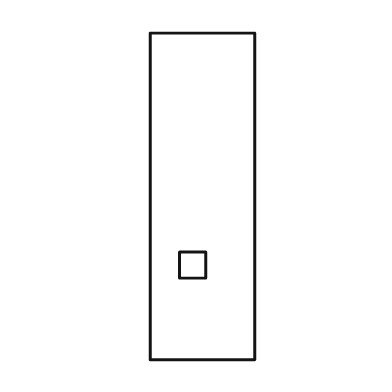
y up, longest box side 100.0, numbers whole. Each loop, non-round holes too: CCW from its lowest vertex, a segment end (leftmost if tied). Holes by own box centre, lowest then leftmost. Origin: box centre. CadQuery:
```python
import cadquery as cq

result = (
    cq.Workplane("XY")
    .moveTo(-16.0, -50.0)
    .lineTo(16.0, -50.0)
    .lineTo(16.0, 50.0)
    .lineTo(-16.0, 50.0)
    .close()
    .moveTo(-7.0, -25.0)
    .lineTo(1.0, -25.0)
    .lineTo(1.0, -17.0)
    .lineTo(-7.0, -17.0)
    .close()
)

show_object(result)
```